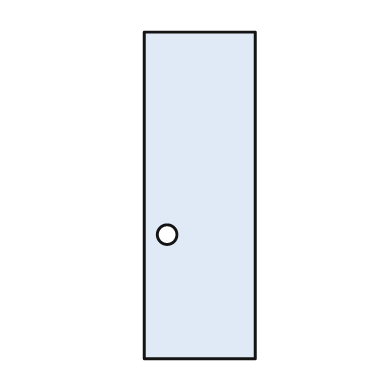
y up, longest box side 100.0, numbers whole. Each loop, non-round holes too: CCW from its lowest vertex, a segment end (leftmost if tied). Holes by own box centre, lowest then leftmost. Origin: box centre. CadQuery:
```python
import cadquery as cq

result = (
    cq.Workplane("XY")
    .moveTo(-17.0, -50.0)
    .lineTo(17.0, -50.0)
    .lineTo(17.0, 50.0)
    .lineTo(-17.0, 50.0)
    .close()
    .moveTo(-10.0, -12.0)
    .circle(3.0)
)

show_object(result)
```